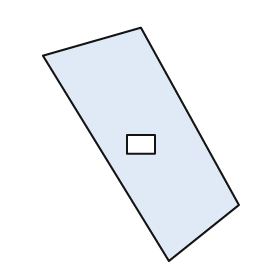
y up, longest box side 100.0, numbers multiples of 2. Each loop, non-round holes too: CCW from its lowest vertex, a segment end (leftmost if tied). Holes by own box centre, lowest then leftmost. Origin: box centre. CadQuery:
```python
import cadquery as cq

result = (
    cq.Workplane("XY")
    .moveTo(12.0, -50.0)
    .lineTo(42.0, -26.0)
    .lineTo(0.0, 50.0)
    .lineTo(-42.0, 38.0)
    .close()
    .moveTo(-6.0, -4.0)
    .lineTo(6.0, -4.0)
    .lineTo(6.0, 4.0)
    .lineTo(-6.0, 4.0)
    .close()
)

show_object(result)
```